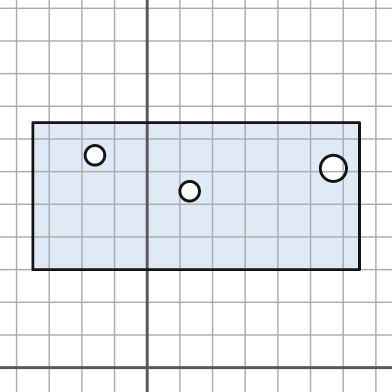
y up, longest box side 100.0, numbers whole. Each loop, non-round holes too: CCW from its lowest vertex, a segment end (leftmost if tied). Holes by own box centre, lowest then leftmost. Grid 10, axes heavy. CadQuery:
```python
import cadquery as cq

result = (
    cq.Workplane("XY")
    .moveTo(-35.0, 30.0)
    .lineTo(65.0, 30.0)
    .lineTo(65.0, 75.0)
    .lineTo(-35.0, 75.0)
    .close()
    .moveTo(13.0, 54.0)
    .circle(3.0)
    .moveTo(57.0, 61.0)
    .circle(4.0)
    .moveTo(-16.0, 65.0)
    .circle(3.0)
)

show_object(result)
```